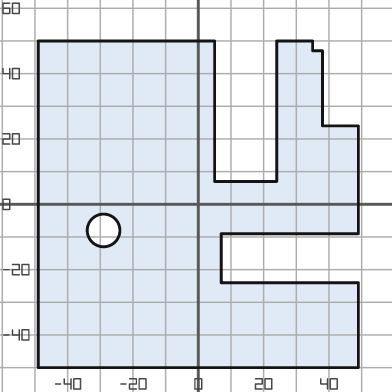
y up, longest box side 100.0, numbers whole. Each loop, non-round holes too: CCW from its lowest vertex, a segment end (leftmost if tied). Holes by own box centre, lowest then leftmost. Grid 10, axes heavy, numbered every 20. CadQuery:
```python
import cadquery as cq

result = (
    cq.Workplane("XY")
    .moveTo(-49.0, -50.0)
    .lineTo(49.0, -50.0)
    .lineTo(49.0, -24.0)
    .lineTo(7.0, -24.0)
    .lineTo(7.0, -9.0)
    .lineTo(49.0, -9.0)
    .lineTo(49.0, 24.0)
    .lineTo(38.0, 24.0)
    .lineTo(38.0, 47.0)
    .lineTo(35.0, 47.0)
    .lineTo(35.0, 50.0)
    .lineTo(24.0, 50.0)
    .lineTo(24.0, 7.0)
    .lineTo(5.0, 7.0)
    .lineTo(5.0, 50.0)
    .lineTo(-49.0, 50.0)
    .close()
    .moveTo(-29.0, -8.0)
    .circle(5.0)
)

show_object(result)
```